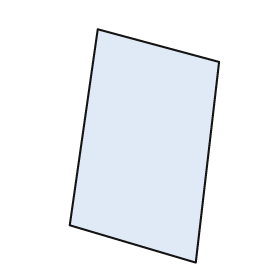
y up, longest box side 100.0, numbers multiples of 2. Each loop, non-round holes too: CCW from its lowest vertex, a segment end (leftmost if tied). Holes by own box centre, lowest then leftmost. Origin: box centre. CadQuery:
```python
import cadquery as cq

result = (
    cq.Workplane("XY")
    .moveTo(22.0, -50.0)
    .lineTo(32.0, 36.0)
    .lineTo(-20.0, 50.0)
    .lineTo(-32.0, -34.0)
    .close()
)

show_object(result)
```